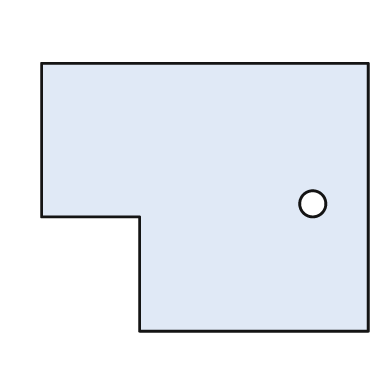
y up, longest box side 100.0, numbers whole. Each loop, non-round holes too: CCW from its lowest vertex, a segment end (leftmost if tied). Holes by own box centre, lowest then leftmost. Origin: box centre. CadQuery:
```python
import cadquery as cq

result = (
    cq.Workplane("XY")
    .moveTo(-20.0, -41.0)
    .lineTo(50.0, -41.0)
    .lineTo(50.0, 41.0)
    .lineTo(-50.0, 41.0)
    .lineTo(-50.0, -6.0)
    .lineTo(-20.0, -6.0)
    .close()
    .moveTo(33.0, -2.0)
    .circle(4.0)
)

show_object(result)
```